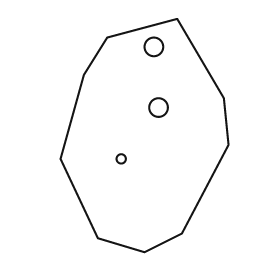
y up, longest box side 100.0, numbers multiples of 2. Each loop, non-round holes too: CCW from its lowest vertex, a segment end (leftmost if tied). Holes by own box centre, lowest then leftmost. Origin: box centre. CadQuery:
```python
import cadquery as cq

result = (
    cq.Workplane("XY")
    .moveTo(0.0, -50.0)
    .lineTo(16.0, -42.0)
    .lineTo(36.0, -4.0)
    .lineTo(34.0, 16.0)
    .lineTo(14.0, 50.0)
    .lineTo(-16.0, 42.0)
    .lineTo(-26.0, 26.0)
    .lineTo(-36.0, -10.0)
    .lineTo(-20.0, -44.0)
    .close()
    .moveTo(-10.0, -10.0)
    .circle(2.0)
    .moveTo(6.0, 12.0)
    .circle(4.0)
    .moveTo(4.0, 38.0)
    .circle(4.0)
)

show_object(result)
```